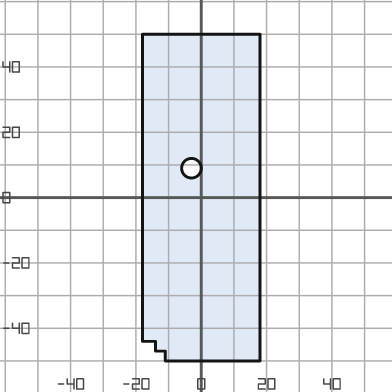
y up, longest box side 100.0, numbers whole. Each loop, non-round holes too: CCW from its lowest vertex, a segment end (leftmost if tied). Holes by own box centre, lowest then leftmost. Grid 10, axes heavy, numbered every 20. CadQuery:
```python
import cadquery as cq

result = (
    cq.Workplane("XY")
    .moveTo(-11.0, -50.0)
    .lineTo(18.0, -50.0)
    .lineTo(18.0, 50.0)
    .lineTo(-18.0, 50.0)
    .lineTo(-18.0, -44.0)
    .lineTo(-14.0, -44.0)
    .lineTo(-14.0, -47.0)
    .lineTo(-11.0, -47.0)
    .close()
    .moveTo(-3.0, 9.0)
    .circle(3.0)
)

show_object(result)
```